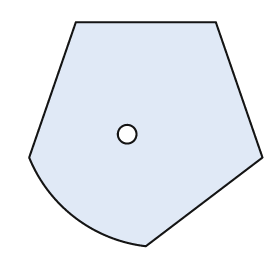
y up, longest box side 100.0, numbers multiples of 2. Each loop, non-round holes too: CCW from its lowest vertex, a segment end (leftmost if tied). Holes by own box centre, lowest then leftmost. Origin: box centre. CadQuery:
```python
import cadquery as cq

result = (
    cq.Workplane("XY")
    .moveTo(0.0, -48.0)
    .lineTo(50.0, -10.0)
    .lineTo(30.0, 48.0)
    .lineTo(-30.0, 48.0)
    .lineTo(-50.0, -10.0)
    .threePointArc((-30.0, -36.0), (0.0, -48.0))
    .close()
    .moveTo(-8.0, 0.0)
    .circle(4.0)
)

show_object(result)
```